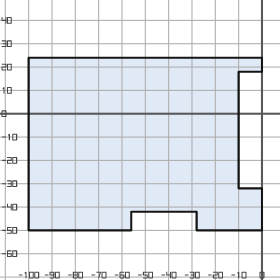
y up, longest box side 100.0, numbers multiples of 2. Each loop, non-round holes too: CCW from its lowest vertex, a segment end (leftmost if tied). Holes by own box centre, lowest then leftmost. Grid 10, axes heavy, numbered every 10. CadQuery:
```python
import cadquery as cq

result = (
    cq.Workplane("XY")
    .moveTo(-100.0, -50.0)
    .lineTo(-56.0, -50.0)
    .lineTo(-56.0, -42.0)
    .lineTo(-28.0, -42.0)
    .lineTo(-28.0, -50.0)
    .lineTo(0.0, -50.0)
    .lineTo(0.0, -32.0)
    .lineTo(-10.0, -32.0)
    .lineTo(-10.0, 18.0)
    .lineTo(0.0, 18.0)
    .lineTo(0.0, 24.0)
    .lineTo(-100.0, 24.0)
    .close()
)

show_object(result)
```